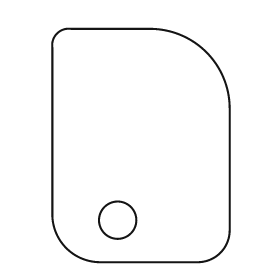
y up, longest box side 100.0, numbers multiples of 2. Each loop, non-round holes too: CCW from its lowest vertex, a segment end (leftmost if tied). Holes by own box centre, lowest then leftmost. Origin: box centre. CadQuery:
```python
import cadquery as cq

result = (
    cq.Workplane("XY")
    .moveTo(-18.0, -50.0)
    .lineTo(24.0, -50.0)
    .threePointArc((34.0, -46.0), (38.0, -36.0))
    .lineTo(38.0, 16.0)
    .threePointArc((28.0, 40.0), (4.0, 50.0))
    .lineTo(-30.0, 50.0)
    .threePointArc((-36.0, 48.0), (-38.0, 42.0))
    .lineTo(-38.0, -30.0)
    .threePointArc((-32.0, -44.0), (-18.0, -50.0))
    .close()
    .moveTo(-10.0, -32.0)
    .circle(8.0)
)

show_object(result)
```